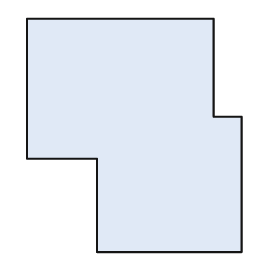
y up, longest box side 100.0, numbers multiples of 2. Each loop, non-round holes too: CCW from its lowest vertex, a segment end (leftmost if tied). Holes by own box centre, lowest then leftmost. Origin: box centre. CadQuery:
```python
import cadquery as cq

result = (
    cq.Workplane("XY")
    .moveTo(-16.0, -50.0)
    .lineTo(46.0, -50.0)
    .lineTo(46.0, 8.0)
    .lineTo(34.0, 8.0)
    .lineTo(34.0, 50.0)
    .lineTo(-46.0, 50.0)
    .lineTo(-46.0, -10.0)
    .lineTo(-16.0, -10.0)
    .close()
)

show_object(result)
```